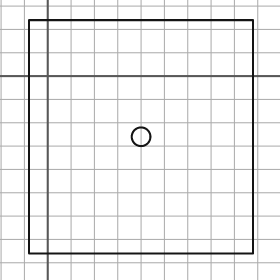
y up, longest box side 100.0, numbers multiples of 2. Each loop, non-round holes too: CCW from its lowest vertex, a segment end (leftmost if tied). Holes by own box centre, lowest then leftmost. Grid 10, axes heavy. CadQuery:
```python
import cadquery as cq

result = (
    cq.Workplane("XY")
    .moveTo(-8.0, -76.0)
    .lineTo(88.0, -76.0)
    .lineTo(88.0, 24.0)
    .lineTo(-8.0, 24.0)
    .close()
    .moveTo(40.0, -26.0)
    .circle(4.0)
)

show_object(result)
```